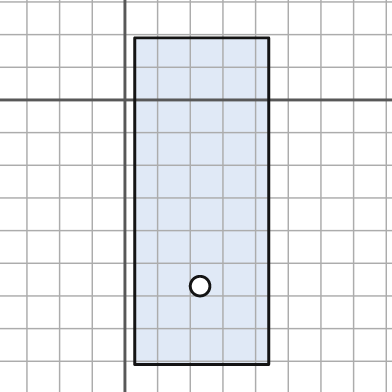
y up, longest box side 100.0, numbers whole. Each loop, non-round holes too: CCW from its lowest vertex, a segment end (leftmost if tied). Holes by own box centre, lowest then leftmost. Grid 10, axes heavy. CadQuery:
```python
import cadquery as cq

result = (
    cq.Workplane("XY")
    .moveTo(3.0, -81.0)
    .lineTo(44.0, -81.0)
    .lineTo(44.0, 19.0)
    .lineTo(3.0, 19.0)
    .close()
    .moveTo(23.0, -57.0)
    .circle(3.0)
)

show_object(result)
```